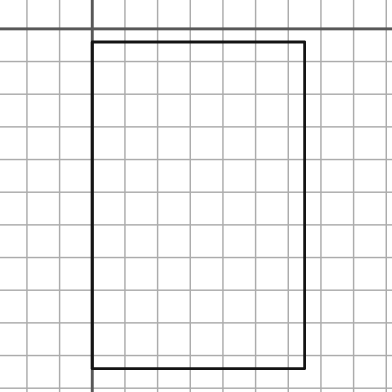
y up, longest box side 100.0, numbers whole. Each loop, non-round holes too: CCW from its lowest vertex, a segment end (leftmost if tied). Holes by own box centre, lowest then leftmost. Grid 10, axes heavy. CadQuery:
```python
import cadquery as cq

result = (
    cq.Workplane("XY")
    .moveTo(0.0, -104.0)
    .lineTo(65.0, -104.0)
    .lineTo(65.0, -4.0)
    .lineTo(0.0, -4.0)
    .close()
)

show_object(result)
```